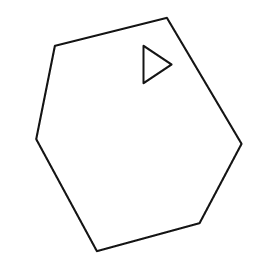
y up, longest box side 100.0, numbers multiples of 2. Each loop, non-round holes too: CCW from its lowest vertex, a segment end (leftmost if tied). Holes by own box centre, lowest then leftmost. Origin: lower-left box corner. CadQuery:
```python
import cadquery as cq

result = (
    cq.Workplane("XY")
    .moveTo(26.0, 0.0)
    .lineTo(70.0, 12.0)
    .lineTo(88.0, 46.0)
    .lineTo(56.0, 100.0)
    .lineTo(8.0, 88.0)
    .lineTo(0.0, 48.0)
    .close()
    .moveTo(46.0, 72.0)
    .lineTo(58.0, 80.0)
    .lineTo(46.0, 88.0)
    .close()
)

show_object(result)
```